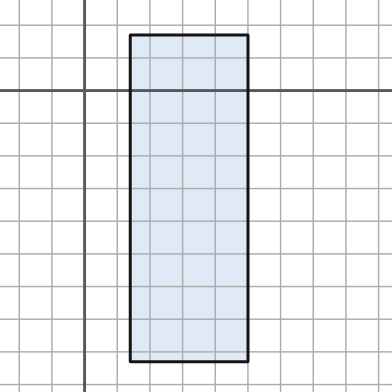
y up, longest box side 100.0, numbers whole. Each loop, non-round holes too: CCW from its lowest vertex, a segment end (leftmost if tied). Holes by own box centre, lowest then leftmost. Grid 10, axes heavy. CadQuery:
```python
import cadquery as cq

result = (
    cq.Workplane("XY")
    .moveTo(14.0, -83.0)
    .lineTo(50.0, -83.0)
    .lineTo(50.0, 17.0)
    .lineTo(14.0, 17.0)
    .close()
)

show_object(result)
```